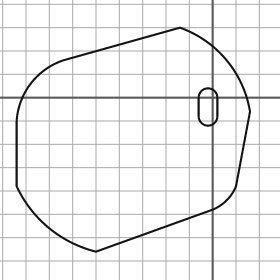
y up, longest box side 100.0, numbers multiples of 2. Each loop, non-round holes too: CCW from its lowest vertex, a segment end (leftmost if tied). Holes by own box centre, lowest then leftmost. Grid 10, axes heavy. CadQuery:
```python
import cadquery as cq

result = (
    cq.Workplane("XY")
    .moveTo(-50.0, -66.0)
    .lineTo(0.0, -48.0)
    .threePointArc((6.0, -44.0), (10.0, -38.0))
    .lineTo(16.0, -6.0)
    .threePointArc((6.0, 16.0), (-14.0, 30.0))
    .lineTo(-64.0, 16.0)
    .threePointArc((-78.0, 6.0), (-84.0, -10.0))
    .lineTo(-84.0, -38.0)
    .threePointArc((-70.0, -56.0), (-50.0, -66.0))
    .close()
    .moveTo(-6.0, -8.0)
    .threePointArc((-2.0, -12.0), (2.0, -8.0))
    .lineTo(2.0, 0.0)
    .threePointArc((-2.0, 4.0), (-6.0, 0.0))
    .close()
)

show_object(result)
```